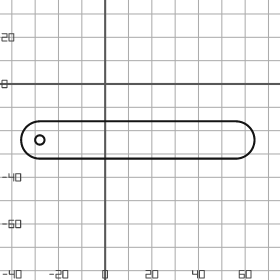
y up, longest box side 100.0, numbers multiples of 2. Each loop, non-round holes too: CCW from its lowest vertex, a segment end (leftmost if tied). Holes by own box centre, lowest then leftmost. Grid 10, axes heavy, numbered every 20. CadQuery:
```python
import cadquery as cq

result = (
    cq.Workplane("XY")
    .moveTo(-28.0, -32.0)
    .lineTo(56.0, -32.0)
    .threePointArc((64.0, -24.0), (56.0, -16.0))
    .lineTo(-28.0, -16.0)
    .threePointArc((-36.0, -24.0), (-28.0, -32.0))
    .close()
    .moveTo(-28.0, -24.0)
    .circle(2.0)
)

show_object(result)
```